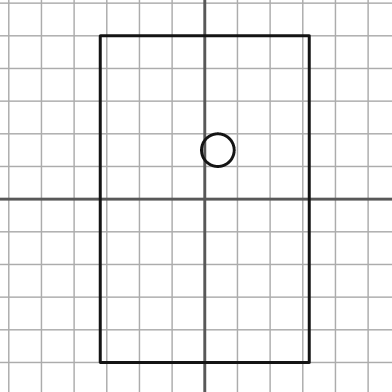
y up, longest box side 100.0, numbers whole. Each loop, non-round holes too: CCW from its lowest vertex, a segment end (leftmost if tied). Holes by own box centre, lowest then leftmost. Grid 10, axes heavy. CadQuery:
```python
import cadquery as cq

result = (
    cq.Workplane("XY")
    .moveTo(-32.0, -50.0)
    .lineTo(32.0, -50.0)
    .lineTo(32.0, 50.0)
    .lineTo(-32.0, 50.0)
    .close()
    .moveTo(4.0, 15.0)
    .circle(5.0)
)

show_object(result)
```